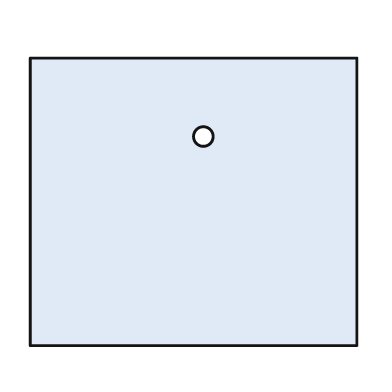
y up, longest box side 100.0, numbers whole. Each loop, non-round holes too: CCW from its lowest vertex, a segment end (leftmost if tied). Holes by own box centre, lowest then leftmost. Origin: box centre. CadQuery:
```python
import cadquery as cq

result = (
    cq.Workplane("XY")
    .moveTo(-50.0, -44.0)
    .lineTo(50.0, -44.0)
    .lineTo(50.0, 44.0)
    .lineTo(-50.0, 44.0)
    .close()
    .moveTo(3.0, 20.0)
    .circle(3.0)
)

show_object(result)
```